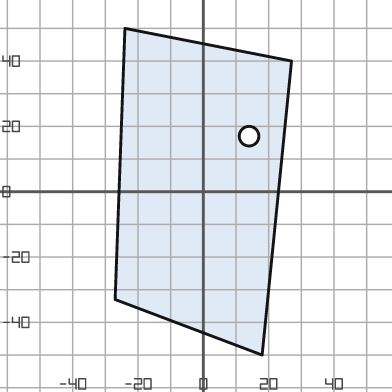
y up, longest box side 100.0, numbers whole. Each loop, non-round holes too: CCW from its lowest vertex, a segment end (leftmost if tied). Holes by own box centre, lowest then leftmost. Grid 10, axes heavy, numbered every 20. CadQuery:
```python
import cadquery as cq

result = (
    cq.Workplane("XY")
    .moveTo(18.0, -50.0)
    .lineTo(27.0, 40.0)
    .lineTo(-24.0, 50.0)
    .lineTo(-27.0, -33.0)
    .close()
    .moveTo(14.0, 17.0)
    .circle(3.0)
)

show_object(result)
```